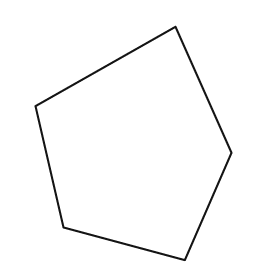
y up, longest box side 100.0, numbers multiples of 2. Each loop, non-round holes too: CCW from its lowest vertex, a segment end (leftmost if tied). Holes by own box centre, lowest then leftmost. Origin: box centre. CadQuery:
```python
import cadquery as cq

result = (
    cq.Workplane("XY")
    .moveTo(22.0, -50.0)
    .lineTo(42.0, -4.0)
    .lineTo(18.0, 50.0)
    .lineTo(-42.0, 16.0)
    .lineTo(-30.0, -36.0)
    .close()
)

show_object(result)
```